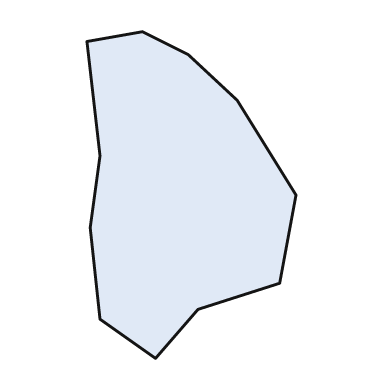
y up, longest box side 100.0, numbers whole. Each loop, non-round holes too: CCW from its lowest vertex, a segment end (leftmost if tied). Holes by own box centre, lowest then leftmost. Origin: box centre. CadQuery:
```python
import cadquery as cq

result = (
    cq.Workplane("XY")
    .moveTo(-11.0, -50.0)
    .lineTo(2.0, -35.0)
    .lineTo(27.0, -27.0)
    .lineTo(32.0, 0.0)
    .lineTo(14.0, 29.0)
    .lineTo(-1.0, 43.0)
    .lineTo(-15.0, 50.0)
    .lineTo(-32.0, 47.0)
    .lineTo(-28.0, 12.0)
    .lineTo(-31.0, -10.0)
    .lineTo(-28.0, -38.0)
    .close()
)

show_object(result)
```